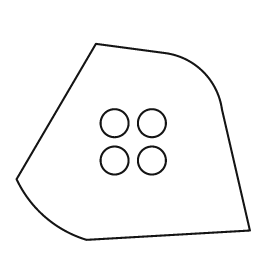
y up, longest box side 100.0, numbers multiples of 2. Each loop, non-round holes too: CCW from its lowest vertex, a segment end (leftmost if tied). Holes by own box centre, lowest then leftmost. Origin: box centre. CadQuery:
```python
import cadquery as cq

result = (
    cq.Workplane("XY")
    .moveTo(-20.0, -42.0)
    .lineTo(50.0, -38.0)
    .lineTo(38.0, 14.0)
    .threePointArc((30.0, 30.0), (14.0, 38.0))
    .lineTo(-16.0, 42.0)
    .lineTo(-50.0, -16.0)
    .threePointArc((-38.0, -32.0), (-20.0, -42.0))
    .close()
    .moveTo(-8.0, -8.0)
    .circle(6.0)
    .moveTo(8.0, -8.0)
    .circle(6.0)
    .moveTo(-8.0, 8.0)
    .circle(6.0)
    .moveTo(8.0, 8.0)
    .circle(6.0)
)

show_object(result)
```